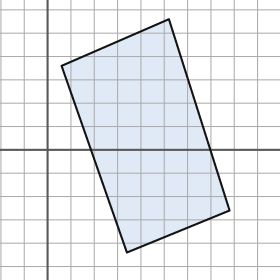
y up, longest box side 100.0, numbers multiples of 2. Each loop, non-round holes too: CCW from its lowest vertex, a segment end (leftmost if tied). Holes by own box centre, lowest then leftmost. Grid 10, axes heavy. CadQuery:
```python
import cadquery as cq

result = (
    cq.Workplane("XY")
    .moveTo(34.0, -44.0)
    .lineTo(78.0, -26.0)
    .lineTo(52.0, 56.0)
    .lineTo(6.0, 36.0)
    .close()
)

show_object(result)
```